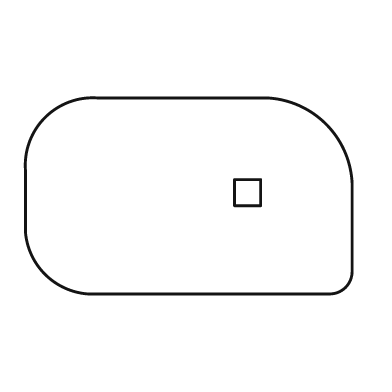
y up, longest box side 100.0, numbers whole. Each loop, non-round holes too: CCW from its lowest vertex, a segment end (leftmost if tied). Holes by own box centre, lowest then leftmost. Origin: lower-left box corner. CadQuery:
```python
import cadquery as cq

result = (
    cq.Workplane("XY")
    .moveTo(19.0, 0.0)
    .lineTo(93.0, 0.0)
    .threePointArc((98.0, 2.0), (100.0, 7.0))
    .lineTo(100.0, 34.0)
    .threePointArc((92.0, 52.0), (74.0, 60.0))
    .lineTo(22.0, 60.0)
    .threePointArc((6.0, 54.0), (0.0, 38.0))
    .lineTo(0.0, 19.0)
    .threePointArc((6.0, 6.0), (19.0, 0.0))
    .close()
    .moveTo(64.0, 27.0)
    .lineTo(72.0, 27.0)
    .lineTo(72.0, 35.0)
    .lineTo(64.0, 35.0)
    .close()
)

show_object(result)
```